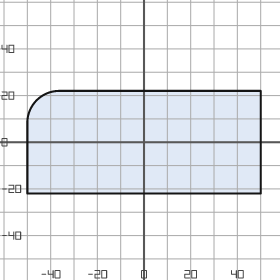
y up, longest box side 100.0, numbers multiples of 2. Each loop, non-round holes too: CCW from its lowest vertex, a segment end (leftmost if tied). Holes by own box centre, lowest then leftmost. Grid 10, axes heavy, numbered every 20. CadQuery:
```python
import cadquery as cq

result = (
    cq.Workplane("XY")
    .moveTo(-50.0, -22.0)
    .lineTo(50.0, -22.0)
    .lineTo(50.0, 22.0)
    .lineTo(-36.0, 22.0)
    .threePointArc((-46.0, 18.0), (-50.0, 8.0))
    .close()
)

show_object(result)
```